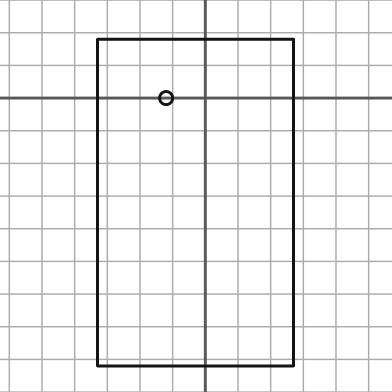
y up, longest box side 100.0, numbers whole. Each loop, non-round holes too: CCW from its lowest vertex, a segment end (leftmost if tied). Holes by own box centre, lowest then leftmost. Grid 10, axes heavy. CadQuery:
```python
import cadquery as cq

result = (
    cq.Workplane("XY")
    .moveTo(-33.0, -82.0)
    .lineTo(27.0, -82.0)
    .lineTo(27.0, 18.0)
    .lineTo(-33.0, 18.0)
    .close()
    .moveTo(-12.0, 0.0)
    .circle(2.0)
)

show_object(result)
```